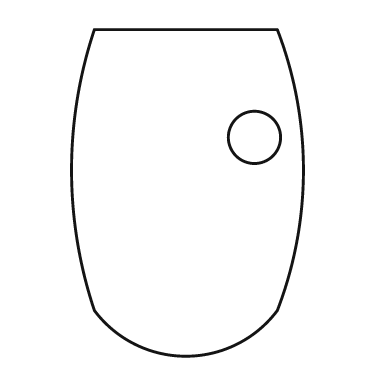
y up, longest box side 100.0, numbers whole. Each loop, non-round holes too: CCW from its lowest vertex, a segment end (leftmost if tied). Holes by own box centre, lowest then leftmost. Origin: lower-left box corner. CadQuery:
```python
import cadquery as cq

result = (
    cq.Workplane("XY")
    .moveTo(7.0, 14.0)
    .threePointArc((35.0, 0.0), (63.0, 14.0))
    .threePointArc((71.0, 57.0), (63.0, 100.0))
    .lineTo(7.0, 100.0)
    .threePointArc((0.0, 57.0), (7.0, 14.0))
    .close()
    .moveTo(56.0, 67.0)
    .circle(8.0)
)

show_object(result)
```